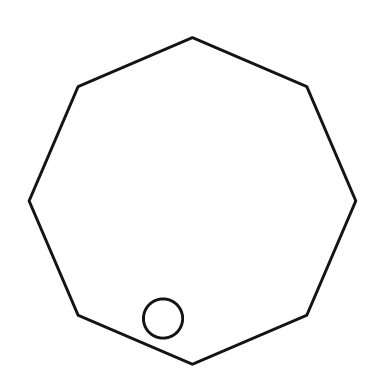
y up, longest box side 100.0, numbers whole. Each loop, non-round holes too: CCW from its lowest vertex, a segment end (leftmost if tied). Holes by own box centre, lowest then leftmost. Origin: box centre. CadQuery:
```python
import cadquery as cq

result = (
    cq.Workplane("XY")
    .moveTo(0.0, -50.0)
    .lineTo(35.0, -35.0)
    .lineTo(50.0, 0.0)
    .lineTo(35.0, 35.0)
    .lineTo(0.0, 50.0)
    .lineTo(-35.0, 35.0)
    .lineTo(-50.0, 0.0)
    .lineTo(-35.0, -35.0)
    .close()
    .moveTo(-9.0, -36.0)
    .circle(6.0)
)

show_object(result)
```